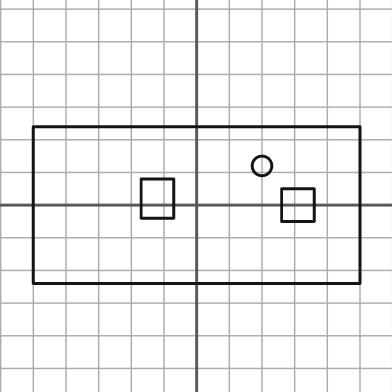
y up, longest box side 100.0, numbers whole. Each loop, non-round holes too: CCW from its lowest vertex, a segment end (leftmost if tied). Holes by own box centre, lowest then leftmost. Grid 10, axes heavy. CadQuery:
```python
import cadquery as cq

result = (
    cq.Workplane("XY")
    .moveTo(-50.0, -24.0)
    .lineTo(50.0, -24.0)
    .lineTo(50.0, 24.0)
    .lineTo(-50.0, 24.0)
    .close()
    .moveTo(26.0, -5.0)
    .lineTo(36.0, -5.0)
    .lineTo(36.0, 5.0)
    .lineTo(26.0, 5.0)
    .close()
    .moveTo(-17.0, -4.0)
    .lineTo(-7.0, -4.0)
    .lineTo(-7.0, 8.0)
    .lineTo(-17.0, 8.0)
    .close()
    .moveTo(20.0, 12.0)
    .circle(3.0)
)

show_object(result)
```